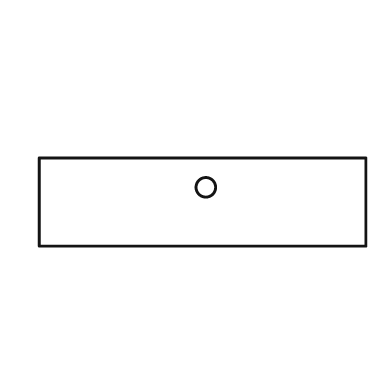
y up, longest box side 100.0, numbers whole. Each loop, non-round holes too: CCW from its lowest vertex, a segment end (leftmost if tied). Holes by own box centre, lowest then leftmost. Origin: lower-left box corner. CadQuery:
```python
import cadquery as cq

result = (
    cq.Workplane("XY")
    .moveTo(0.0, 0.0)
    .lineTo(100.0, 0.0)
    .lineTo(100.0, 27.0)
    .lineTo(0.0, 27.0)
    .close()
    .moveTo(51.0, 18.0)
    .circle(3.0)
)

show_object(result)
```